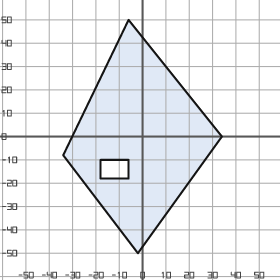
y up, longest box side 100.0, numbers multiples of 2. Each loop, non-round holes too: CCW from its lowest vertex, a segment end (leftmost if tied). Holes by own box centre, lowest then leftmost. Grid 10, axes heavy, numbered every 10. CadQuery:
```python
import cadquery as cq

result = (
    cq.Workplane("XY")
    .moveTo(-2.0, -50.0)
    .lineTo(34.0, 0.0)
    .lineTo(-6.0, 50.0)
    .lineTo(-34.0, -8.0)
    .close()
    .moveTo(-18.0, -18.0)
    .lineTo(-6.0, -18.0)
    .lineTo(-6.0, -10.0)
    .lineTo(-18.0, -10.0)
    .close()
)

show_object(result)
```